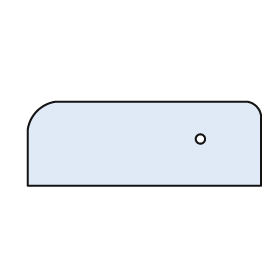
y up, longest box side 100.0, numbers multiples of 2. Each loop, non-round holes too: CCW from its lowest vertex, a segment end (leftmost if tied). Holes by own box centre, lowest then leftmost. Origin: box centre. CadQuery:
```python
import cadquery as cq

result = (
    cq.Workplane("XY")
    .moveTo(-50.0, -18.0)
    .lineTo(50.0, -18.0)
    .lineTo(50.0, 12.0)
    .threePointArc((48.0, 16.0), (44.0, 18.0))
    .lineTo(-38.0, 18.0)
    .threePointArc((-46.0, 14.0), (-50.0, 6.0))
    .close()
    .moveTo(24.0, 2.0)
    .circle(2.0)
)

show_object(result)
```